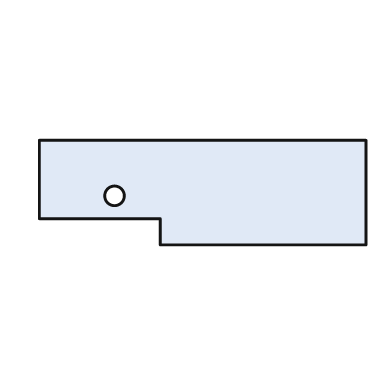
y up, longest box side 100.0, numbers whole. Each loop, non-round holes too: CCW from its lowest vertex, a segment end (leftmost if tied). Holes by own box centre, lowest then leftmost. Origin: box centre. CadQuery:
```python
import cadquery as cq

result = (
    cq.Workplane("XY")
    .moveTo(-13.0, -16.0)
    .lineTo(50.0, -16.0)
    .lineTo(50.0, 16.0)
    .lineTo(-50.0, 16.0)
    .lineTo(-50.0, -8.0)
    .lineTo(-13.0, -8.0)
    .close()
    .moveTo(-27.0, -1.0)
    .circle(3.0)
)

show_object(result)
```